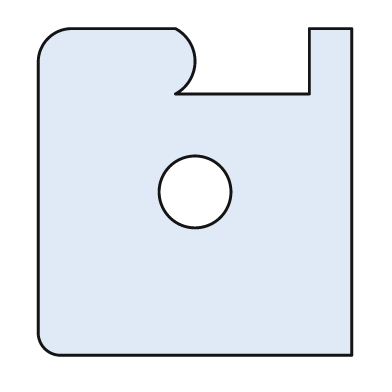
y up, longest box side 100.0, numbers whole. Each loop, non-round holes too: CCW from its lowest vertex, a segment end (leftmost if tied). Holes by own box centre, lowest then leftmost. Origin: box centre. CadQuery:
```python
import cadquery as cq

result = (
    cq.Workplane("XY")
    .moveTo(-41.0, -50.0)
    .lineTo(48.0, -50.0)
    .lineTo(48.0, 50.0)
    .lineTo(35.0, 50.0)
    .lineTo(35.0, 30.0)
    .lineTo(-6.0, 30.0)
    .threePointArc((0.0, 40.0), (-6.0, 50.0))
    .lineTo(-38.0, 50.0)
    .threePointArc((-45.0, 47.0), (-48.0, 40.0))
    .lineTo(-48.0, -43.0)
    .threePointArc((-46.0, -48.0), (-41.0, -50.0))
    .close()
    .moveTo(0.0, 0.0)
    .circle(11.0)
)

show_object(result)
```